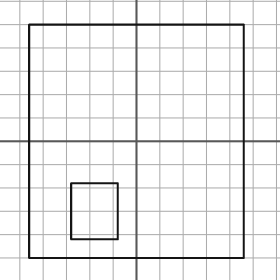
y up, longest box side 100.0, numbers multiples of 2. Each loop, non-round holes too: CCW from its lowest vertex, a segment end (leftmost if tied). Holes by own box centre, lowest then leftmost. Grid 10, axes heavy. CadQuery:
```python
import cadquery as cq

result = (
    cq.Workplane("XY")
    .moveTo(-46.0, -50.0)
    .lineTo(46.0, -50.0)
    .lineTo(46.0, 50.0)
    .lineTo(-46.0, 50.0)
    .close()
    .moveTo(-28.0, -42.0)
    .lineTo(-8.0, -42.0)
    .lineTo(-8.0, -18.0)
    .lineTo(-28.0, -18.0)
    .close()
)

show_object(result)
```